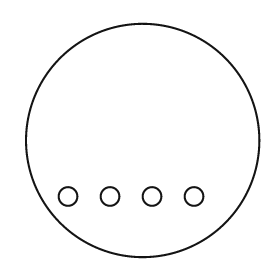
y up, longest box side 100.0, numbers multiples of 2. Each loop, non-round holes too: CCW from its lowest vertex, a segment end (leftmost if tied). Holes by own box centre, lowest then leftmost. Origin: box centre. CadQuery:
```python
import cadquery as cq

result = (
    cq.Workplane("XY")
    .moveTo(0.0, 0.0)
    .circle(50.0)
    .moveTo(-32.0, -24.0)
    .circle(4.0)
    .moveTo(-14.0, -24.0)
    .circle(4.0)
    .moveTo(4.0, -24.0)
    .circle(4.0)
    .moveTo(22.0, -24.0)
    .circle(4.0)
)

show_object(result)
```